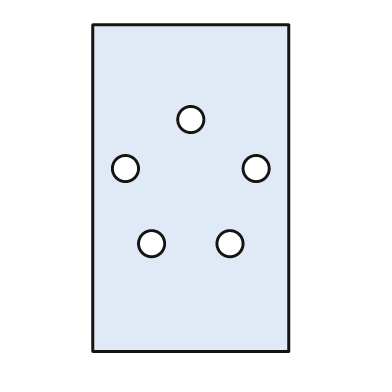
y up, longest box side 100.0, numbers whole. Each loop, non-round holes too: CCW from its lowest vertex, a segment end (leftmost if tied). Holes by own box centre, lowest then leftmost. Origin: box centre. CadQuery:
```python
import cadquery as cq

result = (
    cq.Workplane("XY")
    .moveTo(-30.0, -50.0)
    .lineTo(30.0, -50.0)
    .lineTo(30.0, 50.0)
    .lineTo(-30.0, 50.0)
    .close()
    .moveTo(-12.0, -17.0)
    .circle(4.0)
    .moveTo(12.0, -17.0)
    .circle(4.0)
    .moveTo(-20.0, 6.0)
    .circle(4.0)
    .moveTo(20.0, 6.0)
    .circle(4.0)
    .moveTo(0.0, 21.0)
    .circle(4.0)
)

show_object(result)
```